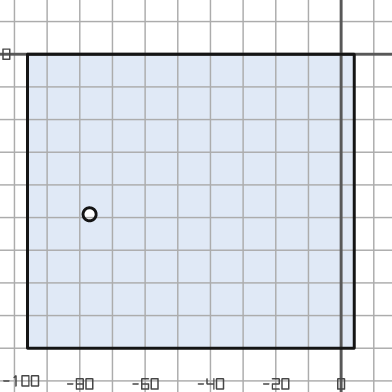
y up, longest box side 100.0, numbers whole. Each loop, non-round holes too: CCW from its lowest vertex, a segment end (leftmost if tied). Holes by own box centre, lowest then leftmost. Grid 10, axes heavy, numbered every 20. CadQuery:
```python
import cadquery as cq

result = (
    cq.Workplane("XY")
    .moveTo(-96.0, -90.0)
    .lineTo(4.0, -90.0)
    .lineTo(4.0, 0.0)
    .lineTo(-96.0, 0.0)
    .close()
    .moveTo(-77.0, -49.0)
    .circle(2.0)
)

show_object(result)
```